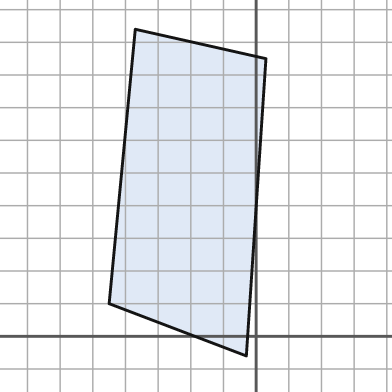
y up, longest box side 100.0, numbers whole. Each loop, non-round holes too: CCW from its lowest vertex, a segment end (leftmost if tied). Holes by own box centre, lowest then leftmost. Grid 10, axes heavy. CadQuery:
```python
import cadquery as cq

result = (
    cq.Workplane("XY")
    .moveTo(-3.0, -6.0)
    .lineTo(3.0, 85.0)
    .lineTo(-37.0, 94.0)
    .lineTo(-45.0, 10.0)
    .close()
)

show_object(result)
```